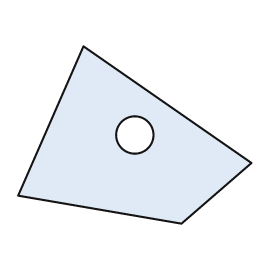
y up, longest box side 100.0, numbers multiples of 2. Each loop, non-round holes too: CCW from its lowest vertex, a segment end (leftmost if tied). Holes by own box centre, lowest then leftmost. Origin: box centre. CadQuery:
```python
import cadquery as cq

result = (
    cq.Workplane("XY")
    .moveTo(20.0, -38.0)
    .lineTo(50.0, -12.0)
    .lineTo(-22.0, 38.0)
    .lineTo(-50.0, -26.0)
    .close()
    .moveTo(0.0, 0.0)
    .circle(8.0)
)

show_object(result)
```